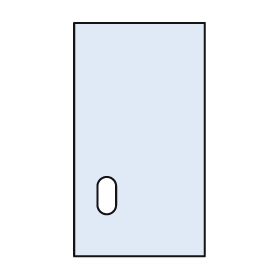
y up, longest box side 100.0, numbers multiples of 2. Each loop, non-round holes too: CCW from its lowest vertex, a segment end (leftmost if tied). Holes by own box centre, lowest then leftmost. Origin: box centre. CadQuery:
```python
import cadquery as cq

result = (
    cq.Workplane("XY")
    .moveTo(-28.0, -50.0)
    .lineTo(28.0, -50.0)
    .lineTo(28.0, 50.0)
    .lineTo(-28.0, 50.0)
    .close()
    .moveTo(-18.0, -28.0)
    .threePointArc((-14.0, -32.0), (-10.0, -28.0))
    .lineTo(-10.0, -20.0)
    .threePointArc((-14.0, -16.0), (-18.0, -20.0))
    .close()
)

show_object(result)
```